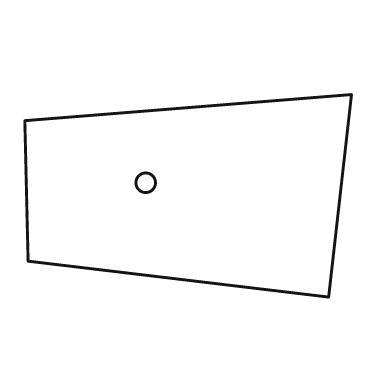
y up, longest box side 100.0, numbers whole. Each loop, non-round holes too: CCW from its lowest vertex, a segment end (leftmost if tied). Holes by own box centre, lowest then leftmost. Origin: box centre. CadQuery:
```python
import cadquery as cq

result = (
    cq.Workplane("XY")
    .moveTo(43.0, -31.0)
    .lineTo(50.0, 31.0)
    .lineTo(-50.0, 23.0)
    .lineTo(-49.0, -20.0)
    .close()
    .moveTo(-13.0, 4.0)
    .circle(3.0)
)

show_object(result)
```